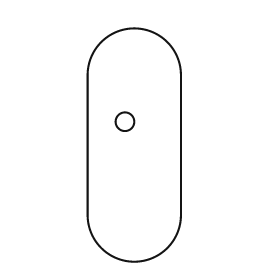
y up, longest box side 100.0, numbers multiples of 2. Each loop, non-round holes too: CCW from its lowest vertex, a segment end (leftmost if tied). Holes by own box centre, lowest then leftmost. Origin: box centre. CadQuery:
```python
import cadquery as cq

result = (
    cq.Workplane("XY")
    .moveTo(-20.0, -30.0)
    .threePointArc((0.0, -50.0), (20.0, -30.0))
    .lineTo(20.0, 30.0)
    .threePointArc((0.0, 50.0), (-20.0, 30.0))
    .close()
    .moveTo(-4.0, 10.0)
    .circle(4.0)
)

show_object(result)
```